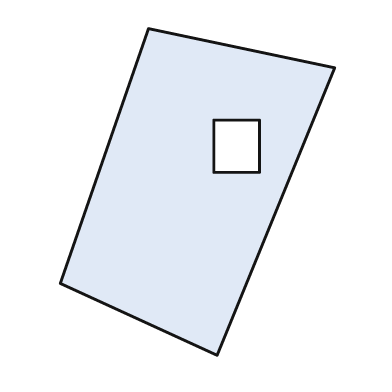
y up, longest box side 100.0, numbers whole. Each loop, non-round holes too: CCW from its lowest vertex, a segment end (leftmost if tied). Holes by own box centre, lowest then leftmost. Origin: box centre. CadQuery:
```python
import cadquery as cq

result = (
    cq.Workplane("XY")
    .moveTo(6.0, -50.0)
    .lineTo(42.0, 38.0)
    .lineTo(-15.0, 50.0)
    .lineTo(-42.0, -28.0)
    .close()
    .moveTo(5.0, 6.0)
    .lineTo(19.0, 6.0)
    .lineTo(19.0, 22.0)
    .lineTo(5.0, 22.0)
    .close()
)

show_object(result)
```